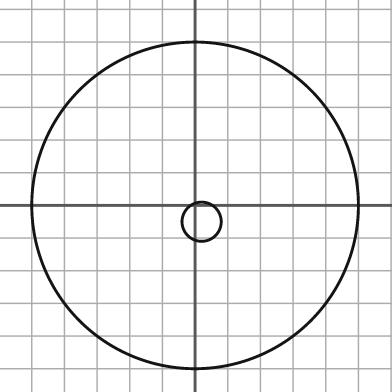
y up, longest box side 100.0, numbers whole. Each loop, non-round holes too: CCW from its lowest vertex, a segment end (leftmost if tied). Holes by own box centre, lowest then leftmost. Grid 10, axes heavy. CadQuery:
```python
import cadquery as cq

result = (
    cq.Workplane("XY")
    .moveTo(0.0, 0.0)
    .circle(50.0)
    .moveTo(2.0, -5.0)
    .circle(6.0)
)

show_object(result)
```